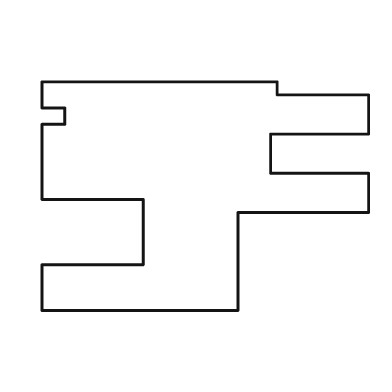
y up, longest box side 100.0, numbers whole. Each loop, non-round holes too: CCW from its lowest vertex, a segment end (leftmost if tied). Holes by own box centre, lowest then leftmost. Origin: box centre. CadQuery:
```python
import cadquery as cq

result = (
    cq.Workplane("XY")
    .moveTo(-50.0, -35.0)
    .lineTo(10.0, -35.0)
    .lineTo(10.0, -5.0)
    .lineTo(50.0, -5.0)
    .lineTo(50.0, 7.0)
    .lineTo(20.0, 7.0)
    .lineTo(20.0, 19.0)
    .lineTo(50.0, 19.0)
    .lineTo(50.0, 31.0)
    .lineTo(22.0, 31.0)
    .lineTo(22.0, 35.0)
    .lineTo(-50.0, 35.0)
    .lineTo(-50.0, 27.0)
    .lineTo(-43.0, 27.0)
    .lineTo(-43.0, 22.0)
    .lineTo(-50.0, 22.0)
    .lineTo(-50.0, -1.0)
    .lineTo(-19.0, -1.0)
    .lineTo(-19.0, -21.0)
    .lineTo(-50.0, -21.0)
    .close()
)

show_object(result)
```